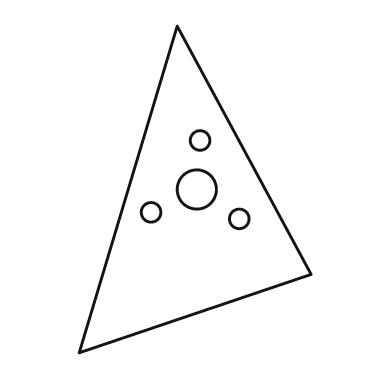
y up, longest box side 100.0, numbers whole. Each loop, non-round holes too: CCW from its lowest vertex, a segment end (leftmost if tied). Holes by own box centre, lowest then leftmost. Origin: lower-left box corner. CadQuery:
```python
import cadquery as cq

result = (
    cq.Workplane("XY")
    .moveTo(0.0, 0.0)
    .lineTo(71.0, 24.0)
    .lineTo(30.0, 100.0)
    .close()
    .moveTo(49.0, 41.0)
    .circle(3.0)
    .moveTo(22.0, 43.0)
    .circle(3.0)
    .moveTo(36.0, 50.0)
    .circle(6.0)
    .moveTo(37.0, 65.0)
    .circle(3.0)
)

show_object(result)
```